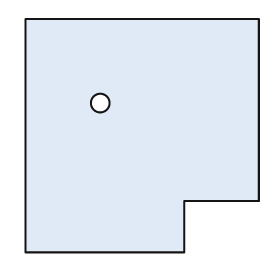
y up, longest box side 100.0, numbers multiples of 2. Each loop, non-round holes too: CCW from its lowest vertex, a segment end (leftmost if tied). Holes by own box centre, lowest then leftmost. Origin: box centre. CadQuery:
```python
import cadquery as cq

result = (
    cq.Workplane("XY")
    .moveTo(-50.0, -50.0)
    .lineTo(18.0, -50.0)
    .lineTo(18.0, -28.0)
    .lineTo(50.0, -28.0)
    .lineTo(50.0, 50.0)
    .lineTo(-50.0, 50.0)
    .close()
    .moveTo(-18.0, 14.0)
    .circle(4.0)
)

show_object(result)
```